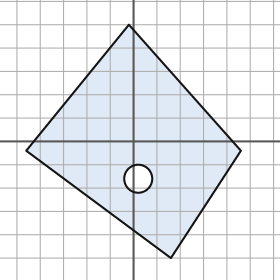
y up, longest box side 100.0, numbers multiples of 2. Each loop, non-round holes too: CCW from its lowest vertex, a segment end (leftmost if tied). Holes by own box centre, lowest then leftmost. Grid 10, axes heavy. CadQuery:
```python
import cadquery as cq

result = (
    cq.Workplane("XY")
    .moveTo(16.0, -50.0)
    .lineTo(46.0, -4.0)
    .lineTo(-2.0, 50.0)
    .lineTo(-46.0, -4.0)
    .close()
    .moveTo(2.0, -16.0)
    .circle(6.0)
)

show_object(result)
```